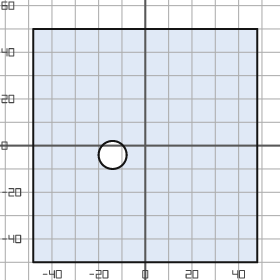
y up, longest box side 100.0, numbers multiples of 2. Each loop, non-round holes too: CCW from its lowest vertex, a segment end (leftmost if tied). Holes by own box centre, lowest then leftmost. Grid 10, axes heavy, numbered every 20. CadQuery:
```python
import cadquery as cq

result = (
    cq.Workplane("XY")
    .moveTo(-48.0, -50.0)
    .lineTo(48.0, -50.0)
    .lineTo(48.0, 50.0)
    .lineTo(-48.0, 50.0)
    .close()
    .moveTo(-14.0, -4.0)
    .circle(6.0)
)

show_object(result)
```